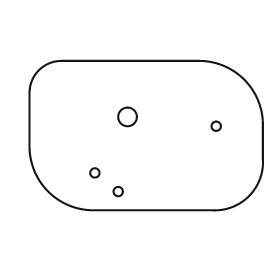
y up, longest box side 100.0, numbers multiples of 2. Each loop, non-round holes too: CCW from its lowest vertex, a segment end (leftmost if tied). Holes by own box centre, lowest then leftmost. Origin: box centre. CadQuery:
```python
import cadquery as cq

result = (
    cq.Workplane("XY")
    .moveTo(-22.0, -32.0)
    .lineTo(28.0, -32.0)
    .threePointArc((44.0, -26.0), (50.0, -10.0))
    .lineTo(50.0, 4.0)
    .threePointArc((42.0, 24.0), (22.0, 32.0))
    .lineTo(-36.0, 32.0)
    .threePointArc((-46.0, 28.0), (-50.0, 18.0))
    .lineTo(-50.0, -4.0)
    .threePointArc((-42.0, -24.0), (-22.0, -32.0))
    .close()
    .moveTo(-12.0, -24.0)
    .circle(2.0)
    .moveTo(-22.0, -16.0)
    .circle(2.0)
    .moveTo(30.0, 4.0)
    .circle(2.0)
    .moveTo(-8.0, 8.0)
    .circle(4.0)
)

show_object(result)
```